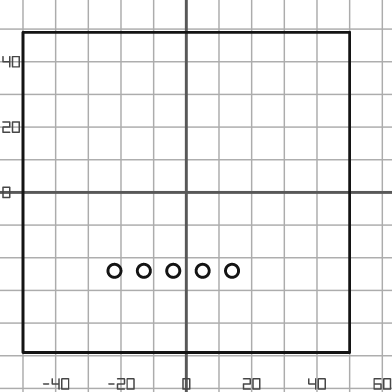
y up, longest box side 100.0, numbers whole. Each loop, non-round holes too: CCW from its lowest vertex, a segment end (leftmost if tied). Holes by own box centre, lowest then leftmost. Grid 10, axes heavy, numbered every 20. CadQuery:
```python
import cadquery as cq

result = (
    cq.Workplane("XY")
    .moveTo(-50.0, -49.0)
    .lineTo(50.0, -49.0)
    .lineTo(50.0, 49.0)
    .lineTo(-50.0, 49.0)
    .close()
    .moveTo(-22.0, -24.0)
    .circle(2.0)
    .moveTo(-13.0, -24.0)
    .circle(2.0)
    .moveTo(-4.0, -24.0)
    .circle(2.0)
    .moveTo(5.0, -24.0)
    .circle(2.0)
    .moveTo(14.0, -24.0)
    .circle(2.0)
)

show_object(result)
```